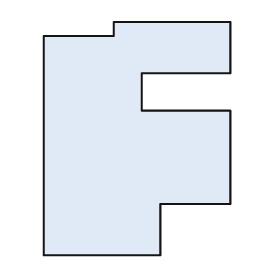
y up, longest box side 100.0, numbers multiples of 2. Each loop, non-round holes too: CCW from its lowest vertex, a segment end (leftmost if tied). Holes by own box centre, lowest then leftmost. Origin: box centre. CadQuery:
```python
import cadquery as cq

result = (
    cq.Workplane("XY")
    .moveTo(-40.0, -50.0)
    .lineTo(10.0, -50.0)
    .lineTo(10.0, -28.0)
    .lineTo(40.0, -28.0)
    .lineTo(40.0, 12.0)
    .lineTo(2.0, 12.0)
    .lineTo(2.0, 28.0)
    .lineTo(40.0, 28.0)
    .lineTo(40.0, 50.0)
    .lineTo(-10.0, 50.0)
    .lineTo(-10.0, 44.0)
    .lineTo(-40.0, 44.0)
    .close()
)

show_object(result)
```